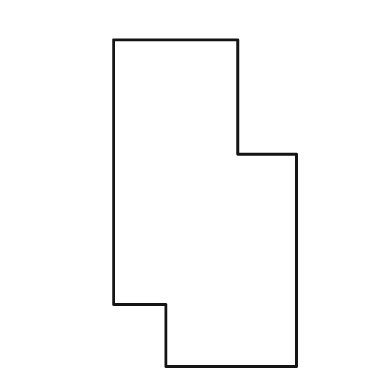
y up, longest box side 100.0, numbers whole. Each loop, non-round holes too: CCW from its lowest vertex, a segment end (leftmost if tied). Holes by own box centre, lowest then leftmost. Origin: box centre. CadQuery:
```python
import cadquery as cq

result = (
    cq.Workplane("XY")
    .moveTo(-12.0, -50.0)
    .lineTo(28.0, -50.0)
    .lineTo(28.0, 15.0)
    .lineTo(10.0, 15.0)
    .lineTo(10.0, 50.0)
    .lineTo(-28.0, 50.0)
    .lineTo(-28.0, -31.0)
    .lineTo(-12.0, -31.0)
    .close()
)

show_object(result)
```